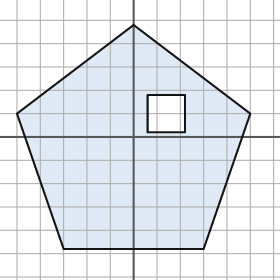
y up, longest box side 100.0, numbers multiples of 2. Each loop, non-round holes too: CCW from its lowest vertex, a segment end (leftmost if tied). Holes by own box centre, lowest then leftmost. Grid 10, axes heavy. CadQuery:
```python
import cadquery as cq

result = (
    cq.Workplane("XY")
    .moveTo(-30.0, -48.0)
    .lineTo(30.0, -48.0)
    .lineTo(50.0, 10.0)
    .lineTo(0.0, 48.0)
    .lineTo(-50.0, 10.0)
    .close()
    .moveTo(6.0, 2.0)
    .lineTo(22.0, 2.0)
    .lineTo(22.0, 18.0)
    .lineTo(6.0, 18.0)
    .close()
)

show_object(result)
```